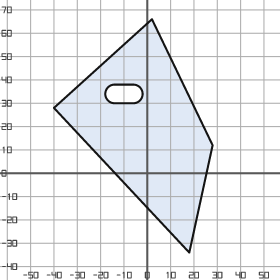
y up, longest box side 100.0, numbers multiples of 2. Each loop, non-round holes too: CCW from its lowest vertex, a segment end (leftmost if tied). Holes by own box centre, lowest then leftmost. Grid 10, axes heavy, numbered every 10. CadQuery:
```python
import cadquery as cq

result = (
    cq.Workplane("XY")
    .moveTo(18.0, -34.0)
    .lineTo(28.0, 12.0)
    .lineTo(2.0, 66.0)
    .lineTo(-40.0, 28.0)
    .close()
    .moveTo(-14.0, 30.0)
    .lineTo(-6.0, 30.0)
    .threePointArc((-2.0, 34.0), (-6.0, 38.0))
    .lineTo(-14.0, 38.0)
    .threePointArc((-18.0, 34.0), (-14.0, 30.0))
    .close()
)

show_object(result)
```